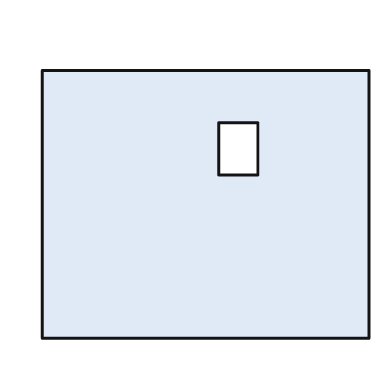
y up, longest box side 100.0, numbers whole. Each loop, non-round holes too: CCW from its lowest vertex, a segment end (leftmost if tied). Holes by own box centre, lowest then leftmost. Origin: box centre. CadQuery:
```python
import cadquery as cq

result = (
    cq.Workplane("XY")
    .moveTo(-50.0, -41.0)
    .lineTo(50.0, -41.0)
    .lineTo(50.0, 41.0)
    .lineTo(-50.0, 41.0)
    .close()
    .moveTo(4.0, 9.0)
    .lineTo(16.0, 9.0)
    .lineTo(16.0, 25.0)
    .lineTo(4.0, 25.0)
    .close()
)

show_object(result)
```